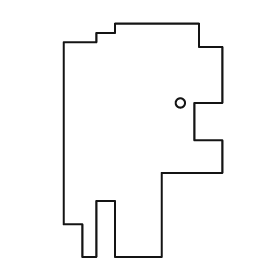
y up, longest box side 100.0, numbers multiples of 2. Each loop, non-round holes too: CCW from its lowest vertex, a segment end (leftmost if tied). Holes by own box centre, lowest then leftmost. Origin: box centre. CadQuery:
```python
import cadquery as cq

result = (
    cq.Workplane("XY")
    .moveTo(-26.0, -50.0)
    .lineTo(-20.0, -50.0)
    .lineTo(-20.0, -26.0)
    .lineTo(-12.0, -26.0)
    .lineTo(-12.0, -50.0)
    .lineTo(8.0, -50.0)
    .lineTo(8.0, -14.0)
    .lineTo(34.0, -14.0)
    .lineTo(34.0, 0.0)
    .lineTo(22.0, 0.0)
    .lineTo(22.0, 16.0)
    .lineTo(34.0, 16.0)
    .lineTo(34.0, 40.0)
    .lineTo(24.0, 40.0)
    .lineTo(24.0, 50.0)
    .lineTo(-12.0, 50.0)
    .lineTo(-12.0, 46.0)
    .lineTo(-20.0, 46.0)
    .lineTo(-20.0, 42.0)
    .lineTo(-34.0, 42.0)
    .lineTo(-34.0, -36.0)
    .lineTo(-26.0, -36.0)
    .close()
    .moveTo(16.0, 16.0)
    .circle(2.0)
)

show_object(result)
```